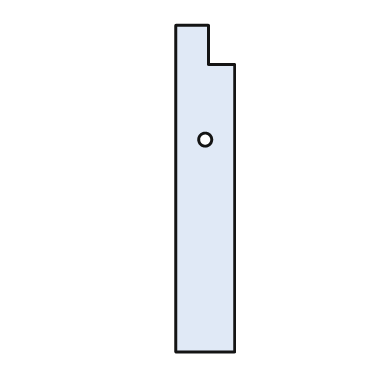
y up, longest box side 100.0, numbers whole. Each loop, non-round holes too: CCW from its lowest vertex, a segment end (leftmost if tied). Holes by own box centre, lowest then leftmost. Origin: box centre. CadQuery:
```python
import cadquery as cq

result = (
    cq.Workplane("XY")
    .moveTo(-9.0, -50.0)
    .lineTo(9.0, -50.0)
    .lineTo(9.0, 38.0)
    .lineTo(1.0, 38.0)
    .lineTo(1.0, 50.0)
    .lineTo(-9.0, 50.0)
    .close()
    .moveTo(0.0, 15.0)
    .circle(2.0)
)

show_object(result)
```